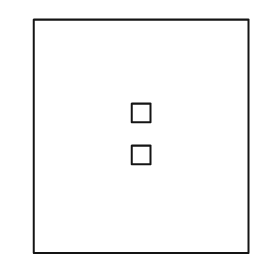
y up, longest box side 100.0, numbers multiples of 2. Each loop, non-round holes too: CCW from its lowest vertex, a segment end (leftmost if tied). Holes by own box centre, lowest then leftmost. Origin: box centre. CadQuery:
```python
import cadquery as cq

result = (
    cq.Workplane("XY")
    .moveTo(-46.0, -50.0)
    .lineTo(46.0, -50.0)
    .lineTo(46.0, 50.0)
    .lineTo(-46.0, 50.0)
    .close()
    .moveTo(-4.0, -12.0)
    .lineTo(4.0, -12.0)
    .lineTo(4.0, -4.0)
    .lineTo(-4.0, -4.0)
    .close()
    .moveTo(-4.0, 6.0)
    .lineTo(4.0, 6.0)
    .lineTo(4.0, 14.0)
    .lineTo(-4.0, 14.0)
    .close()
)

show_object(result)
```